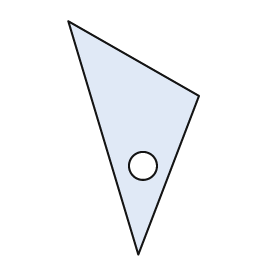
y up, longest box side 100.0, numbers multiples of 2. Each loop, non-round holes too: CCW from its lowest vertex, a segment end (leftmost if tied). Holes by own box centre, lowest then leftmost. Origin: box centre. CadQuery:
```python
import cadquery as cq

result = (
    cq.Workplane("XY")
    .moveTo(2.0, -50.0)
    .lineTo(28.0, 18.0)
    .lineTo(-28.0, 50.0)
    .close()
    .moveTo(4.0, -12.0)
    .circle(6.0)
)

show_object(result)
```